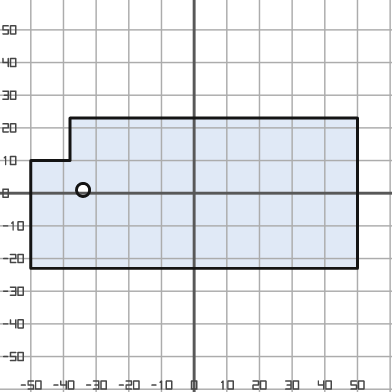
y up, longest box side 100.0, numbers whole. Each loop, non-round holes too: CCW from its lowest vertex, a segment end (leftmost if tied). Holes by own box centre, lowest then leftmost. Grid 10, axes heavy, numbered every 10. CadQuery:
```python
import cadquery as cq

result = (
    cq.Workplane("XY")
    .moveTo(-50.0, -23.0)
    .lineTo(50.0, -23.0)
    .lineTo(50.0, 23.0)
    .lineTo(-38.0, 23.0)
    .lineTo(-38.0, 10.0)
    .lineTo(-50.0, 10.0)
    .close()
    .moveTo(-34.0, 1.0)
    .circle(2.0)
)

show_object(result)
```